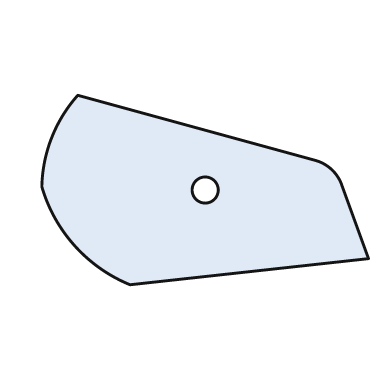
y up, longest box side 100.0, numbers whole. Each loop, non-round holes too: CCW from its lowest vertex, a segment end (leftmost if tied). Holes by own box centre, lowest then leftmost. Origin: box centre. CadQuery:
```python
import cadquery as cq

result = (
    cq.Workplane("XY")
    .moveTo(-23.0, -29.0)
    .lineTo(50.0, -21.0)
    .lineTo(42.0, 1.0)
    .threePointArc((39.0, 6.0), (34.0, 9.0))
    .lineTo(-39.0, 29.0)
    .threePointArc((-47.0, 16.0), (-50.0, 1.0))
    .threePointArc((-40.0, -17.0), (-23.0, -29.0))
    .close()
    .moveTo(0.0, 0.0)
    .circle(4.0)
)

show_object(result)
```